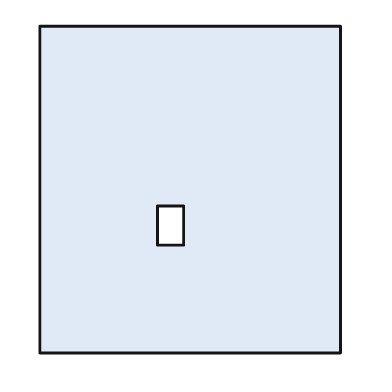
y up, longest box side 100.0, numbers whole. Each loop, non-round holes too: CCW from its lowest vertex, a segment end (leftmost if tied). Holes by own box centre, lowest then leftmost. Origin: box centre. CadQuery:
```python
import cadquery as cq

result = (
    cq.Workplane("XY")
    .moveTo(-46.0, -50.0)
    .lineTo(46.0, -50.0)
    .lineTo(46.0, 50.0)
    .lineTo(-46.0, 50.0)
    .close()
    .moveTo(-10.0, -17.0)
    .lineTo(-2.0, -17.0)
    .lineTo(-2.0, -5.0)
    .lineTo(-10.0, -5.0)
    .close()
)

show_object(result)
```